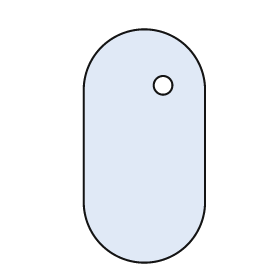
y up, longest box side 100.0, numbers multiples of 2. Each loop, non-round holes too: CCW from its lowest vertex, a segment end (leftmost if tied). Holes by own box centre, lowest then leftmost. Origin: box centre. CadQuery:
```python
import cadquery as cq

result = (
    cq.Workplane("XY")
    .moveTo(-26.0, -24.0)
    .threePointArc((0.0, -50.0), (26.0, -24.0))
    .lineTo(26.0, 24.0)
    .threePointArc((0.0, 50.0), (-26.0, 24.0))
    .close()
    .moveTo(8.0, 26.0)
    .circle(4.0)
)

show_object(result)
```